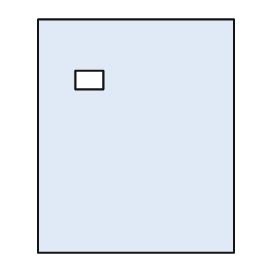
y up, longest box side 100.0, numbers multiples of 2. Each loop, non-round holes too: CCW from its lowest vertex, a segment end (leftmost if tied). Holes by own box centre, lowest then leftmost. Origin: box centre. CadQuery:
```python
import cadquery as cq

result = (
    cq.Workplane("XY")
    .moveTo(-42.0, -50.0)
    .lineTo(42.0, -50.0)
    .lineTo(42.0, 50.0)
    .lineTo(-42.0, 50.0)
    .close()
    .moveTo(-26.0, 20.0)
    .lineTo(-14.0, 20.0)
    .lineTo(-14.0, 28.0)
    .lineTo(-26.0, 28.0)
    .close()
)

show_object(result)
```